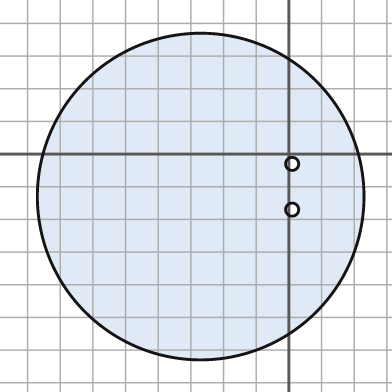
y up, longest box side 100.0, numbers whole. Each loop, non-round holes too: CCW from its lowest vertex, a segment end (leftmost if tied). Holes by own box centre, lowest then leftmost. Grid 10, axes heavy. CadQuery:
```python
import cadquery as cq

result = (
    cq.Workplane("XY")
    .moveTo(-27.0, -13.0)
    .circle(50.0)
    .moveTo(1.0, -17.0)
    .circle(2.0)
    .moveTo(1.0, -3.0)
    .circle(2.0)
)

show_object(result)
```